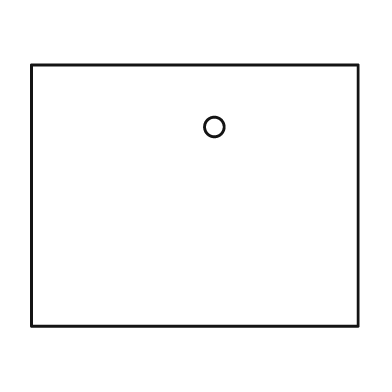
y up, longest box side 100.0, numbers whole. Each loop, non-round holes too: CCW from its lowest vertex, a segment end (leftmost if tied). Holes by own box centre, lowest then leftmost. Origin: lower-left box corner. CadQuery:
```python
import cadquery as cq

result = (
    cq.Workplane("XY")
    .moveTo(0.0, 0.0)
    .lineTo(100.0, 0.0)
    .lineTo(100.0, 80.0)
    .lineTo(0.0, 80.0)
    .close()
    .moveTo(56.0, 61.0)
    .circle(3.0)
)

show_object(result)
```